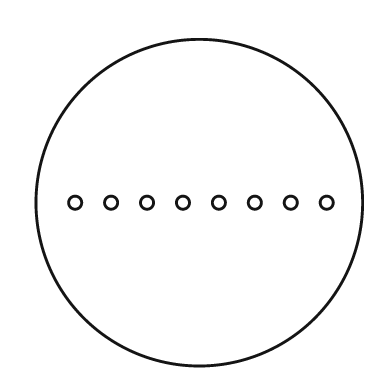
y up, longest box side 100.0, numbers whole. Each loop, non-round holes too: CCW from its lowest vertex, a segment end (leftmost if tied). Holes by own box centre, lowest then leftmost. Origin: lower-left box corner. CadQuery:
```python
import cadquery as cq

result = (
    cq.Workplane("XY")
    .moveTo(50.0, 50.0)
    .circle(50.0)
    .moveTo(12.0, 50.0)
    .circle(2.0)
    .moveTo(23.0, 50.0)
    .circle(2.0)
    .moveTo(34.0, 50.0)
    .circle(2.0)
    .moveTo(45.0, 50.0)
    .circle(2.0)
    .moveTo(56.0, 50.0)
    .circle(2.0)
    .moveTo(67.0, 50.0)
    .circle(2.0)
    .moveTo(78.0, 50.0)
    .circle(2.0)
    .moveTo(89.0, 50.0)
    .circle(2.0)
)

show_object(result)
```